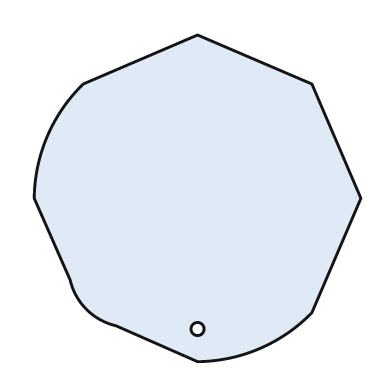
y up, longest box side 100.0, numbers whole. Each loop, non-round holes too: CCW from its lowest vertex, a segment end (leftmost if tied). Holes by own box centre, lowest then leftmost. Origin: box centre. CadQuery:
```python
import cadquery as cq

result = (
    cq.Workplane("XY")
    .moveTo(0.0, -50.0)
    .threePointArc((19.0, -46.0), (35.0, -35.0))
    .lineTo(50.0, 0.0)
    .lineTo(35.0, 35.0)
    .lineTo(0.0, 50.0)
    .lineTo(-35.0, 35.0)
    .threePointArc((-46.0, 19.0), (-50.0, 0.0))
    .lineTo(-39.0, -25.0)
    .threePointArc((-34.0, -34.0), (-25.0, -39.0))
    .close()
    .moveTo(0.0, -40.0)
    .circle(2.0)
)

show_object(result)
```